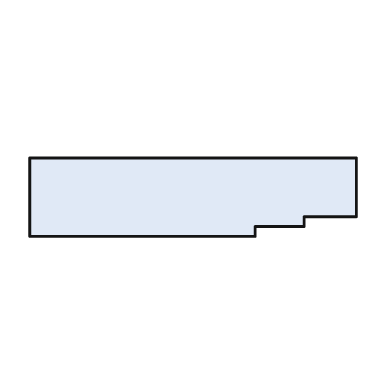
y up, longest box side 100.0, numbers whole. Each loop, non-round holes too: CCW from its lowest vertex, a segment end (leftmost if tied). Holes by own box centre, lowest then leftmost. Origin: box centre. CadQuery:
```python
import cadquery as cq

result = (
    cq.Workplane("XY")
    .moveTo(-50.0, -12.0)
    .lineTo(19.0, -12.0)
    .lineTo(19.0, -9.0)
    .lineTo(34.0, -9.0)
    .lineTo(34.0, -6.0)
    .lineTo(50.0, -6.0)
    .lineTo(50.0, 12.0)
    .lineTo(-50.0, 12.0)
    .close()
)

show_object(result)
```